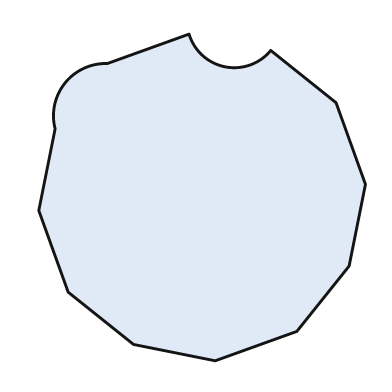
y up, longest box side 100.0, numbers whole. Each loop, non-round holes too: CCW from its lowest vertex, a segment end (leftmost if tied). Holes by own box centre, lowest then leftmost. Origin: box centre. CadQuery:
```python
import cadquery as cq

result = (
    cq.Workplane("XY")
    .moveTo(4.0, -50.0)
    .lineTo(29.0, -41.0)
    .lineTo(45.0, -21.0)
    .lineTo(50.0, 4.0)
    .lineTo(41.0, 29.0)
    .lineTo(21.0, 45.0)
    .threePointArc((7.0, 40.0), (-4.0, 50.0))
    .lineTo(-29.0, 41.0)
    .threePointArc((-42.0, 35.0), (-45.0, 21.0))
    .lineTo(-50.0, -4.0)
    .lineTo(-41.0, -29.0)
    .lineTo(-21.0, -45.0)
    .close()
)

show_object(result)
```